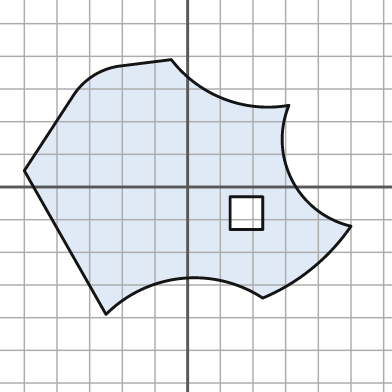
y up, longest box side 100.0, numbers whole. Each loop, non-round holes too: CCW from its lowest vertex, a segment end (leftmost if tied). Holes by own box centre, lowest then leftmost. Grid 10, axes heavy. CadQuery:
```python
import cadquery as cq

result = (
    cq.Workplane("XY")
    .moveTo(-25.0, -39.0)
    .threePointArc((-2.0, -28.0), (23.0, -34.0))
    .threePointArc((38.0, -25.0), (50.0, -12.0))
    .threePointArc((32.0, 2.0), (31.0, 25.0))
    .threePointArc((11.0, 27.0), (-5.0, 39.0))
    .lineTo(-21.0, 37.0)
    .threePointArc((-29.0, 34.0), (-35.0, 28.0))
    .lineTo(-50.0, 5.0)
    .close()
    .moveTo(13.0, -13.0)
    .lineTo(23.0, -13.0)
    .lineTo(23.0, -3.0)
    .lineTo(13.0, -3.0)
    .close()
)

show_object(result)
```